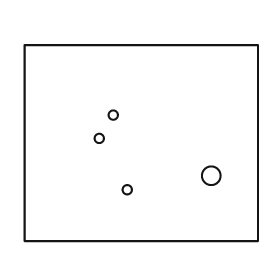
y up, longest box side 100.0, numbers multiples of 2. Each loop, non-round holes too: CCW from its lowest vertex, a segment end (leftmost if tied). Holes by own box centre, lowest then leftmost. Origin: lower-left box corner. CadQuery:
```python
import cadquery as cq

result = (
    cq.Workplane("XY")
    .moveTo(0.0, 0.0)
    .lineTo(100.0, 0.0)
    .lineTo(100.0, 84.0)
    .lineTo(0.0, 84.0)
    .close()
    .moveTo(44.0, 22.0)
    .circle(2.0)
    .moveTo(80.0, 28.0)
    .circle(4.0)
    .moveTo(32.0, 44.0)
    .circle(2.0)
    .moveTo(38.0, 54.0)
    .circle(2.0)
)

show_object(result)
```